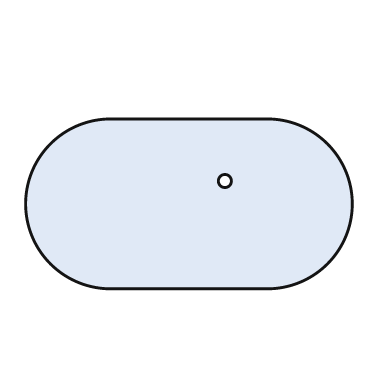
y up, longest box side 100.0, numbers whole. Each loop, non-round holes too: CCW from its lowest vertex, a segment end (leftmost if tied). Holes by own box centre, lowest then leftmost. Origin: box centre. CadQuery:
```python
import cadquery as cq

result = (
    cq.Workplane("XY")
    .moveTo(-24.0, -26.0)
    .lineTo(24.0, -26.0)
    .threePointArc((50.0, 0.0), (24.0, 26.0))
    .lineTo(-24.0, 26.0)
    .threePointArc((-50.0, 0.0), (-24.0, -26.0))
    .close()
    .moveTo(11.0, 7.0)
    .circle(2.0)
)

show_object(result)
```